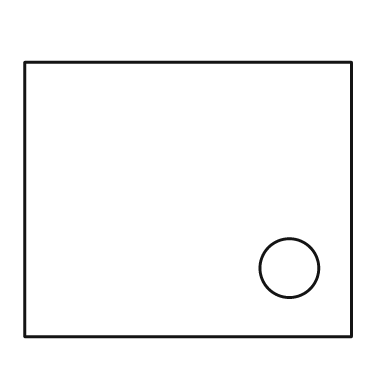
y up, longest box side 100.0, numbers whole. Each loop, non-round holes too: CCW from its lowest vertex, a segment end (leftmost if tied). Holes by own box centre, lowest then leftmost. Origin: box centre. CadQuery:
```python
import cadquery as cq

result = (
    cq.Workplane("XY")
    .moveTo(-50.0, -42.0)
    .lineTo(50.0, -42.0)
    .lineTo(50.0, 42.0)
    .lineTo(-50.0, 42.0)
    .close()
    .moveTo(31.0, -21.0)
    .circle(9.0)
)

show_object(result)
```